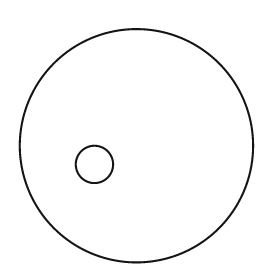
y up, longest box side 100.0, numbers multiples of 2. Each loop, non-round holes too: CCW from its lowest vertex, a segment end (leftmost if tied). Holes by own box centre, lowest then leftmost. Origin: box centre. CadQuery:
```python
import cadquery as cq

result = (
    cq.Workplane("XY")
    .moveTo(0.0, 0.0)
    .circle(50.0)
    .moveTo(-18.0, -8.0)
    .circle(8.0)
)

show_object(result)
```